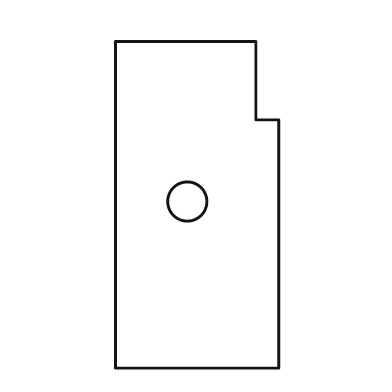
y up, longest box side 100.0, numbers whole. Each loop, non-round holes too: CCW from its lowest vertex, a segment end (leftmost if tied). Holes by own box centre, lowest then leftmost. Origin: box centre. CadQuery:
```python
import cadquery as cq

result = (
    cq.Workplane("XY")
    .moveTo(-25.0, -50.0)
    .lineTo(25.0, -50.0)
    .lineTo(25.0, 26.0)
    .lineTo(18.0, 26.0)
    .lineTo(18.0, 50.0)
    .lineTo(-25.0, 50.0)
    .close()
    .moveTo(-3.0, 1.0)
    .circle(6.0)
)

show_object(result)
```